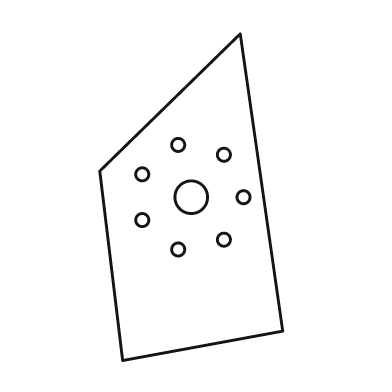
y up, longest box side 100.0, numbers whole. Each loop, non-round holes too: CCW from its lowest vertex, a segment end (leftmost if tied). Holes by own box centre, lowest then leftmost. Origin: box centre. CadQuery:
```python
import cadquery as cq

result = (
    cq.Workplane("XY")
    .moveTo(-21.0, -50.0)
    .lineTo(28.0, -41.0)
    .lineTo(15.0, 50.0)
    .lineTo(-28.0, 8.0)
    .close()
    .moveTo(-4.0, -16.0)
    .circle(2.0)
    .moveTo(10.0, -13.0)
    .circle(2.0)
    .moveTo(-15.0, -7.0)
    .circle(2.0)
    .moveTo(0.0, 0.0)
    .circle(5.0)
    .moveTo(16.0, 0.0)
    .circle(2.0)
    .moveTo(-15.0, 7.0)
    .circle(2.0)
    .moveTo(10.0, 13.0)
    .circle(2.0)
    .moveTo(-4.0, 16.0)
    .circle(2.0)
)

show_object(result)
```